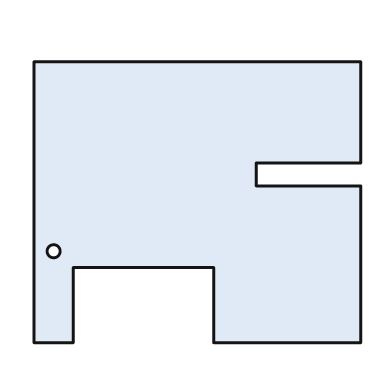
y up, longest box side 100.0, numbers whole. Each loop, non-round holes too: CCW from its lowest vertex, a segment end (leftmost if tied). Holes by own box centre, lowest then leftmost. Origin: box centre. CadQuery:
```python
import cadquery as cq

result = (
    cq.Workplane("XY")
    .moveTo(-50.0, -43.0)
    .lineTo(-38.0, -43.0)
    .lineTo(-38.0, -20.0)
    .lineTo(5.0, -20.0)
    .lineTo(5.0, -43.0)
    .lineTo(50.0, -43.0)
    .lineTo(50.0, 5.0)
    .lineTo(18.0, 5.0)
    .lineTo(18.0, 12.0)
    .lineTo(50.0, 12.0)
    .lineTo(50.0, 43.0)
    .lineTo(-50.0, 43.0)
    .close()
    .moveTo(-44.0, -15.0)
    .circle(2.0)
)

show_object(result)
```